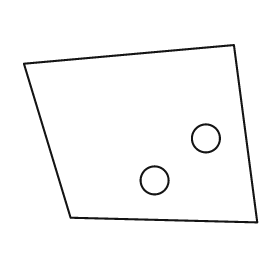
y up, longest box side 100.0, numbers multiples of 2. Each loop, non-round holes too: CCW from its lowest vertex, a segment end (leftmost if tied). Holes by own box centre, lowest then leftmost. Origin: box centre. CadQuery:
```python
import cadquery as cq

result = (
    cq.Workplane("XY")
    .moveTo(50.0, -38.0)
    .lineTo(40.0, 38.0)
    .lineTo(-50.0, 30.0)
    .lineTo(-30.0, -36.0)
    .close()
    .moveTo(6.0, -20.0)
    .circle(6.0)
    .moveTo(28.0, -2.0)
    .circle(6.0)
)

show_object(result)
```